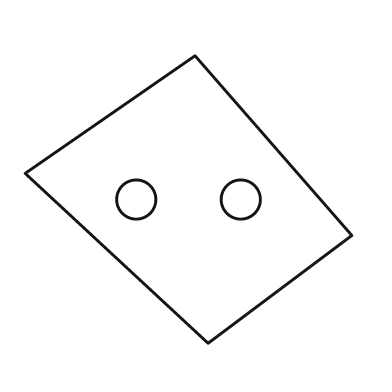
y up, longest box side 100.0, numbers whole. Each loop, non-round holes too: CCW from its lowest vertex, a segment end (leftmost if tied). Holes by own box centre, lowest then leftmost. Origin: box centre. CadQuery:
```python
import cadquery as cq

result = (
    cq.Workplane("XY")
    .moveTo(6.0, -44.0)
    .lineTo(50.0, -11.0)
    .lineTo(2.0, 44.0)
    .lineTo(-50.0, 8.0)
    .close()
    .moveTo(-16.0, 0.0)
    .circle(6.0)
    .moveTo(16.0, 0.0)
    .circle(6.0)
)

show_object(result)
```